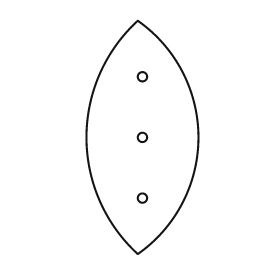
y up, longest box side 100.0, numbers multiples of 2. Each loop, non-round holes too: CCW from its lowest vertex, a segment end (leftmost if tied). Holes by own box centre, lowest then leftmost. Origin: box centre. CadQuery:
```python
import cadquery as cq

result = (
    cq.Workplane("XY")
    .moveTo(-2.0, -50.0)
    .threePointArc((24.0, 0.0), (-2.0, 50.0))
    .threePointArc((-24.0, 0.0), (-2.0, -50.0))
    .close()
    .moveTo(0.0, -26.0)
    .circle(2.0)
    .moveTo(0.0, 0.0)
    .circle(2.0)
    .moveTo(0.0, 26.0)
    .circle(2.0)
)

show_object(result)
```